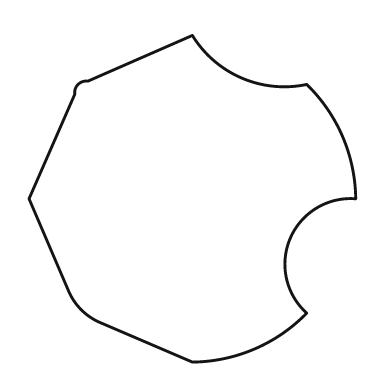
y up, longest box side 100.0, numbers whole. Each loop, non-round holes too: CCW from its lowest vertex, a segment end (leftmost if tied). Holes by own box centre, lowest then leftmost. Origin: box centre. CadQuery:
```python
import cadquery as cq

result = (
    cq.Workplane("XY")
    .moveTo(0.0, -50.0)
    .threePointArc((19.0, -46.0), (35.0, -35.0))
    .threePointArc((30.0, -12.0), (50.0, 0.0))
    .threePointArc((46.0, 19.0), (35.0, 35.0))
    .threePointArc((15.0, 37.0), (0.0, 50.0))
    .lineTo(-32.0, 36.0)
    .threePointArc((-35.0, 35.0), (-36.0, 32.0))
    .lineTo(-50.0, 0.0)
    .lineTo(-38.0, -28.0)
    .threePointArc((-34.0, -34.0), (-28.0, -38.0))
    .close()
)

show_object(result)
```